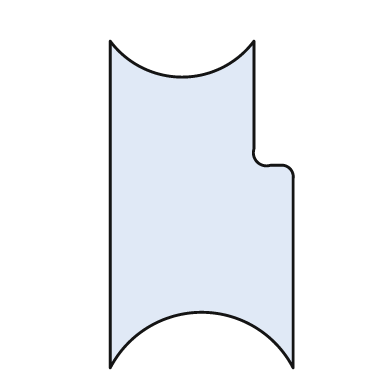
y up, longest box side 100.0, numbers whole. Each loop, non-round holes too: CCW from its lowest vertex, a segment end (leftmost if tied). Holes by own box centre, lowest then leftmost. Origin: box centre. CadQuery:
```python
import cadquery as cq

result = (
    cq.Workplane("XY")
    .moveTo(-28.0, -50.0)
    .threePointArc((0.0, -33.0), (28.0, -50.0))
    .lineTo(28.0, 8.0)
    .threePointArc((27.0, 11.0), (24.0, 12.0))
    .lineTo(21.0, 12.0)
    .threePointArc((17.0, 13.0), (16.0, 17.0))
    .lineTo(16.0, 50.0)
    .threePointArc((-6.0, 39.0), (-28.0, 50.0))
    .close()
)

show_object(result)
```